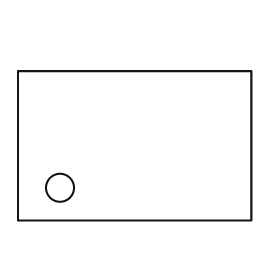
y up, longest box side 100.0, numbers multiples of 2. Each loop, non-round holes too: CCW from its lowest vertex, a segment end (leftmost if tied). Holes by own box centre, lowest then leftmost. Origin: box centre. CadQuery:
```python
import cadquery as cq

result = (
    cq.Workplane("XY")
    .moveTo(-50.0, -32.0)
    .lineTo(50.0, -32.0)
    .lineTo(50.0, 32.0)
    .lineTo(-50.0, 32.0)
    .close()
    .moveTo(-32.0, -18.0)
    .circle(6.0)
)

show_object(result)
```